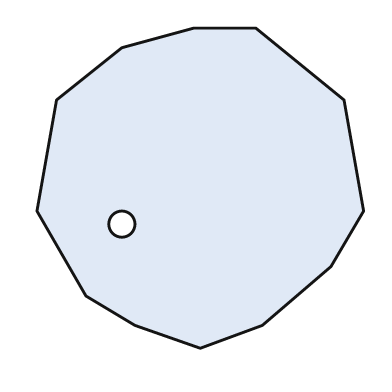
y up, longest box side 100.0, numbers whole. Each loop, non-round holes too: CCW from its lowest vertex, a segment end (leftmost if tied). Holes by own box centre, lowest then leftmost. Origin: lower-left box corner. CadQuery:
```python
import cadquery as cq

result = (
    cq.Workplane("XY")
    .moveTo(50.0, 0.0)
    .lineTo(69.0, 7.0)
    .lineTo(90.0, 25.0)
    .lineTo(100.0, 42.0)
    .lineTo(94.0, 76.0)
    .lineTo(67.0, 98.0)
    .lineTo(48.0, 98.0)
    .lineTo(26.0, 92.0)
    .lineTo(6.0, 76.0)
    .lineTo(0.0, 42.0)
    .lineTo(15.0, 16.0)
    .lineTo(30.0, 7.0)
    .close()
    .moveTo(26.0, 38.0)
    .circle(4.0)
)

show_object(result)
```